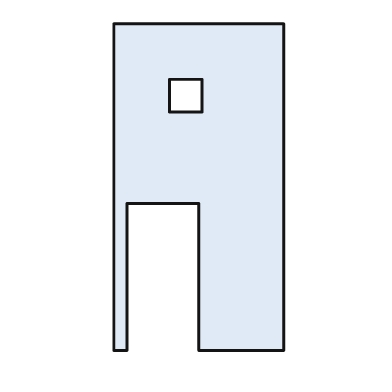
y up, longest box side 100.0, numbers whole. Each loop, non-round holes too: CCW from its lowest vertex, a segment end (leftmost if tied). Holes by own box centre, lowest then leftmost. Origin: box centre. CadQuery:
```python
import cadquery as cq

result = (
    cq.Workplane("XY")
    .moveTo(-26.0, -50.0)
    .lineTo(-22.0, -50.0)
    .lineTo(-22.0, -5.0)
    .lineTo(0.0, -5.0)
    .lineTo(0.0, -50.0)
    .lineTo(26.0, -50.0)
    .lineTo(26.0, 50.0)
    .lineTo(-26.0, 50.0)
    .close()
    .moveTo(-9.0, 23.0)
    .lineTo(1.0, 23.0)
    .lineTo(1.0, 33.0)
    .lineTo(-9.0, 33.0)
    .close()
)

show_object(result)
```